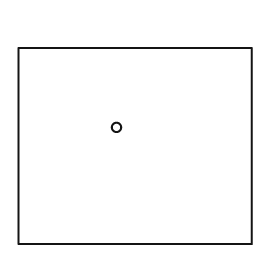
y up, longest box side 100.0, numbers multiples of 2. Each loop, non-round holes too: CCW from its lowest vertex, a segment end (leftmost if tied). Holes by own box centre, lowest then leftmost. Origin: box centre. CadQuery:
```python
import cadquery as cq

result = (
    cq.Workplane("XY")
    .moveTo(-50.0, -42.0)
    .lineTo(50.0, -42.0)
    .lineTo(50.0, 42.0)
    .lineTo(-50.0, 42.0)
    .close()
    .moveTo(-8.0, 8.0)
    .circle(2.0)
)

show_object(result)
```